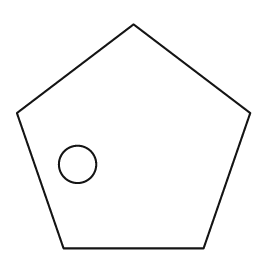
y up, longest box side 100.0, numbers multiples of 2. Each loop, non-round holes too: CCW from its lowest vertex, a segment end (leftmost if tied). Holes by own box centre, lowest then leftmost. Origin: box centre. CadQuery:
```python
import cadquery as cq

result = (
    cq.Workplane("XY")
    .moveTo(-30.0, -48.0)
    .lineTo(30.0, -48.0)
    .lineTo(50.0, 10.0)
    .lineTo(0.0, 48.0)
    .lineTo(-50.0, 10.0)
    .close()
    .moveTo(-24.0, -12.0)
    .circle(8.0)
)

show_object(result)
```